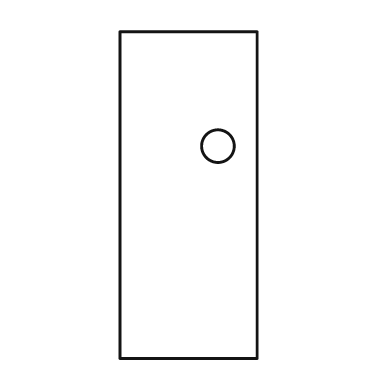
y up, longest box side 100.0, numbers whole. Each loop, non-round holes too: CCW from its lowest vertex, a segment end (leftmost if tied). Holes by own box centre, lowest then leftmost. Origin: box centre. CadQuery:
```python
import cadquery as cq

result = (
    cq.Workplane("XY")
    .moveTo(-21.0, -50.0)
    .lineTo(21.0, -50.0)
    .lineTo(21.0, 50.0)
    .lineTo(-21.0, 50.0)
    .close()
    .moveTo(9.0, 15.0)
    .circle(5.0)
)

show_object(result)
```